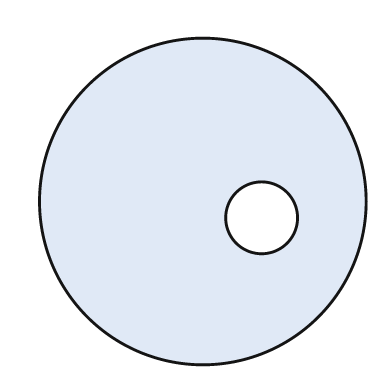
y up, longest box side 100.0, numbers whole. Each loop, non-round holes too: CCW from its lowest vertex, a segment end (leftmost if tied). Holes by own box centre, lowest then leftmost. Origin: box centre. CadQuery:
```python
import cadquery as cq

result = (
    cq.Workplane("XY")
    .moveTo(0.0, 0.0)
    .circle(50.0)
    .moveTo(18.0, -5.0)
    .circle(11.0)
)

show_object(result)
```